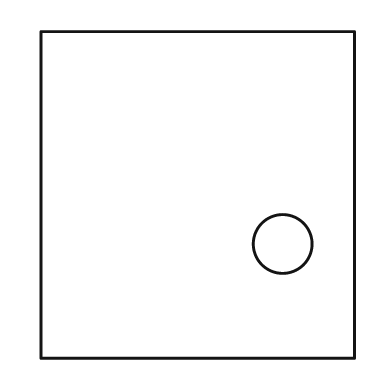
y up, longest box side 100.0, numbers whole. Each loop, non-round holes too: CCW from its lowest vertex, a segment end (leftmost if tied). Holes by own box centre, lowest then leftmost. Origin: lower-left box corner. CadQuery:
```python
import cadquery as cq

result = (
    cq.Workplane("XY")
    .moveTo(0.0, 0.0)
    .lineTo(96.0, 0.0)
    .lineTo(96.0, 100.0)
    .lineTo(0.0, 100.0)
    .close()
    .moveTo(74.0, 35.0)
    .circle(9.0)
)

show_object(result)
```